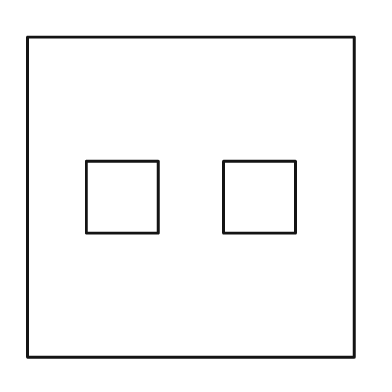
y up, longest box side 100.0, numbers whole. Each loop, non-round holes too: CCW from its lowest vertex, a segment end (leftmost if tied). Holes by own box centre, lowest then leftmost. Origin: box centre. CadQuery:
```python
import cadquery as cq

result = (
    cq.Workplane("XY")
    .moveTo(-50.0, -49.0)
    .lineTo(50.0, -49.0)
    .lineTo(50.0, 49.0)
    .lineTo(-50.0, 49.0)
    .close()
    .moveTo(-32.0, -11.0)
    .lineTo(-10.0, -11.0)
    .lineTo(-10.0, 11.0)
    .lineTo(-32.0, 11.0)
    .close()
    .moveTo(10.0, -11.0)
    .lineTo(32.0, -11.0)
    .lineTo(32.0, 11.0)
    .lineTo(10.0, 11.0)
    .close()
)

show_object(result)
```